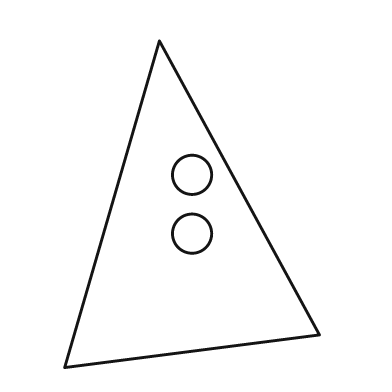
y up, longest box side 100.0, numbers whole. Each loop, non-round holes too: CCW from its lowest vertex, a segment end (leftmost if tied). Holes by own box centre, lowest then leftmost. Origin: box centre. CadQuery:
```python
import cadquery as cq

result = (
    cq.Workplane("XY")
    .moveTo(-39.0, -50.0)
    .lineTo(39.0, -40.0)
    .lineTo(-10.0, 50.0)
    .close()
    .moveTo(0.0, -9.0)
    .circle(6.0)
    .moveTo(0.0, 9.0)
    .circle(6.0)
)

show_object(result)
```